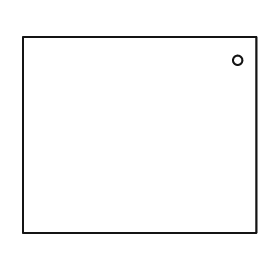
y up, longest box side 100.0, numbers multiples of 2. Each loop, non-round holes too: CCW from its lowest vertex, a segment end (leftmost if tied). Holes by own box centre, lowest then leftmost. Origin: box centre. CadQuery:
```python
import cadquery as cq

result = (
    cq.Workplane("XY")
    .moveTo(-50.0, -42.0)
    .lineTo(50.0, -42.0)
    .lineTo(50.0, 42.0)
    .lineTo(-50.0, 42.0)
    .close()
    .moveTo(42.0, 32.0)
    .circle(2.0)
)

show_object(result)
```